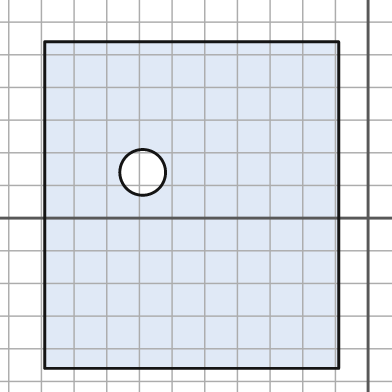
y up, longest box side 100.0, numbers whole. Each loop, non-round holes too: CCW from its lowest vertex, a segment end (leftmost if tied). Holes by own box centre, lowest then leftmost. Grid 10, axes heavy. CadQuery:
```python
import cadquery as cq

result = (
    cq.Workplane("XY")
    .moveTo(-99.0, -46.0)
    .lineTo(-9.0, -46.0)
    .lineTo(-9.0, 54.0)
    .lineTo(-99.0, 54.0)
    .close()
    .moveTo(-69.0, 14.0)
    .circle(7.0)
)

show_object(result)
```